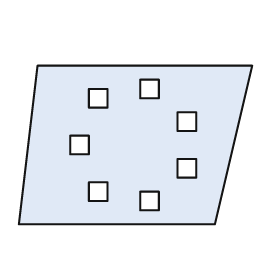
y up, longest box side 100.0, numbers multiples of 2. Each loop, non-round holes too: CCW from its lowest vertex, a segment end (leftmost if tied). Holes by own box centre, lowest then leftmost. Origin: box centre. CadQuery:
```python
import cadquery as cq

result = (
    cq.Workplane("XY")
    .moveTo(-50.0, -34.0)
    .lineTo(34.0, -34.0)
    .lineTo(50.0, 34.0)
    .lineTo(-42.0, 34.0)
    .close()
    .moveTo(2.0, -28.0)
    .lineTo(10.0, -28.0)
    .lineTo(10.0, -20.0)
    .lineTo(2.0, -20.0)
    .close()
    .moveTo(-20.0, -24.0)
    .lineTo(-12.0, -24.0)
    .lineTo(-12.0, -16.0)
    .lineTo(-20.0, -16.0)
    .close()
    .moveTo(18.0, -14.0)
    .lineTo(26.0, -14.0)
    .lineTo(26.0, -6.0)
    .lineTo(18.0, -6.0)
    .close()
    .moveTo(-28.0, -4.0)
    .lineTo(-20.0, -4.0)
    .lineTo(-20.0, 4.0)
    .lineTo(-28.0, 4.0)
    .close()
    .moveTo(18.0, 6.0)
    .lineTo(26.0, 6.0)
    .lineTo(26.0, 14.0)
    .lineTo(18.0, 14.0)
    .close()
    .moveTo(-20.0, 16.0)
    .lineTo(-12.0, 16.0)
    .lineTo(-12.0, 24.0)
    .lineTo(-20.0, 24.0)
    .close()
    .moveTo(2.0, 20.0)
    .lineTo(10.0, 20.0)
    .lineTo(10.0, 28.0)
    .lineTo(2.0, 28.0)
    .close()
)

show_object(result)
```